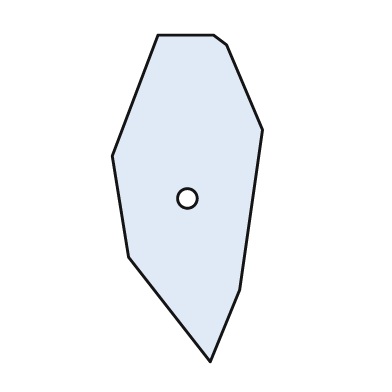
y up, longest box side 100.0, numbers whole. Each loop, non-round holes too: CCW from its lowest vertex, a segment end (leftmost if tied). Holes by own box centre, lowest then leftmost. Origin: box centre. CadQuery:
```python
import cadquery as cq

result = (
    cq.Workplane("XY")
    .moveTo(7.0, -50.0)
    .lineTo(16.0, -28.0)
    .lineTo(23.0, 21.0)
    .lineTo(12.0, 47.0)
    .lineTo(8.0, 50.0)
    .lineTo(-9.0, 50.0)
    .lineTo(-23.0, 13.0)
    .lineTo(-18.0, -18.0)
    .close()
    .moveTo(0.0, 0.0)
    .circle(3.0)
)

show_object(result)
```